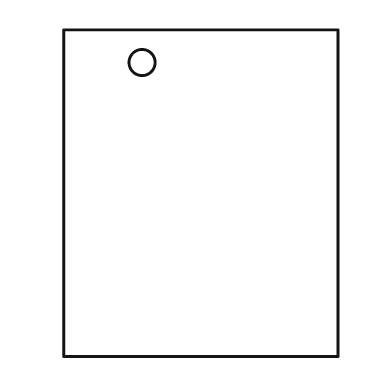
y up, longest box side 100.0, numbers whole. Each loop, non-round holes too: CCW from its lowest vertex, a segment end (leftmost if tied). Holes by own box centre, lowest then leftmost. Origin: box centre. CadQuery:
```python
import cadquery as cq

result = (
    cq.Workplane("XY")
    .moveTo(-42.0, -50.0)
    .lineTo(42.0, -50.0)
    .lineTo(42.0, 50.0)
    .lineTo(-42.0, 50.0)
    .close()
    .moveTo(-18.0, 40.0)
    .circle(4.0)
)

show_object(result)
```